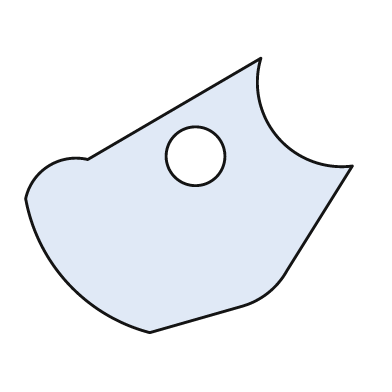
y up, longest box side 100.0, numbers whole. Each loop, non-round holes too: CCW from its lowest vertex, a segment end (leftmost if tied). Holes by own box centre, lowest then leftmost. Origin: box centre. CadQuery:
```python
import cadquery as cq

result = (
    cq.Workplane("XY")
    .moveTo(-12.0, -42.0)
    .lineTo(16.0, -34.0)
    .threePointArc((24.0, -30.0), (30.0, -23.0))
    .lineTo(50.0, 9.0)
    .threePointArc((27.0, 18.0), (22.0, 42.0))
    .lineTo(-31.0, 11.0)
    .threePointArc((-43.0, 9.0), (-50.0, -1.0))
    .threePointArc((-37.0, -27.0), (-12.0, -42.0))
    .close()
    .moveTo(2.0, 12.0)
    .circle(9.0)
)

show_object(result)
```